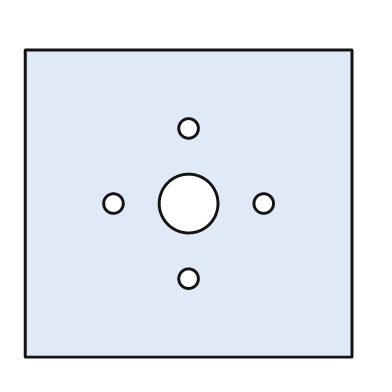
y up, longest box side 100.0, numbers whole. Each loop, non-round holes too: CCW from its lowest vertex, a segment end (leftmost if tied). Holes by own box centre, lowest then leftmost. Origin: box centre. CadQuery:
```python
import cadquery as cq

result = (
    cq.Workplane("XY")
    .moveTo(-50.0, -47.0)
    .lineTo(50.0, -47.0)
    .lineTo(50.0, 47.0)
    .lineTo(-50.0, 47.0)
    .close()
    .moveTo(0.0, -23.0)
    .circle(3.0)
    .moveTo(-23.0, 0.0)
    .circle(3.0)
    .moveTo(0.0, 0.0)
    .circle(9.0)
    .moveTo(23.0, 0.0)
    .circle(3.0)
    .moveTo(0.0, 23.0)
    .circle(3.0)
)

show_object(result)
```